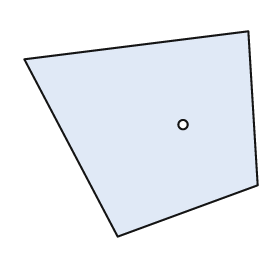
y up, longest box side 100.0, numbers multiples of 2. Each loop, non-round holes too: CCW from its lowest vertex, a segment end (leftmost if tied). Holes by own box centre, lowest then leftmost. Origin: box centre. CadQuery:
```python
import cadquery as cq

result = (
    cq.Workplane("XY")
    .moveTo(-10.0, -44.0)
    .lineTo(50.0, -22.0)
    .lineTo(46.0, 44.0)
    .lineTo(-50.0, 32.0)
    .close()
    .moveTo(18.0, 4.0)
    .circle(2.0)
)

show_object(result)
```